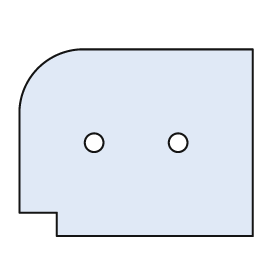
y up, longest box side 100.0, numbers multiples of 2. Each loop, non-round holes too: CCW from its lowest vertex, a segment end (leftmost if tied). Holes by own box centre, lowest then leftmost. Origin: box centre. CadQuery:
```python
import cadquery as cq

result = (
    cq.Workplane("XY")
    .moveTo(-34.0, -40.0)
    .lineTo(50.0, -40.0)
    .lineTo(50.0, 40.0)
    .lineTo(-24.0, 40.0)
    .threePointArc((-42.0, 32.0), (-50.0, 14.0))
    .lineTo(-50.0, -30.0)
    .lineTo(-34.0, -30.0)
    .close()
    .moveTo(-18.0, 0.0)
    .circle(4.0)
    .moveTo(18.0, 0.0)
    .circle(4.0)
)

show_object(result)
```